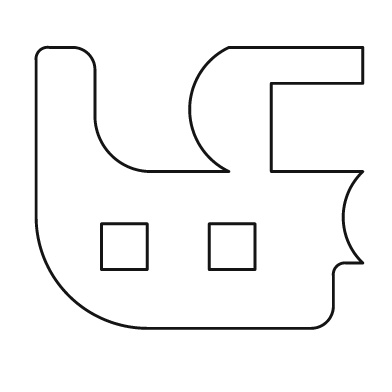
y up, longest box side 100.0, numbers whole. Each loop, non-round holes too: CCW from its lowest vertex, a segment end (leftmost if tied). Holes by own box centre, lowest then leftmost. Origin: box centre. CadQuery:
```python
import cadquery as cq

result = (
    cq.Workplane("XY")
    .moveTo(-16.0, -43.0)
    .lineTo(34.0, -43.0)
    .threePointArc((39.0, -41.0), (41.0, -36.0))
    .lineTo(41.0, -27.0)
    .threePointArc((42.0, -24.0), (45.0, -23.0))
    .lineTo(50.0, -23.0)
    .threePointArc((44.0, -9.0), (50.0, 5.0))
    .lineTo(22.0, 5.0)
    .lineTo(22.0, 32.0)
    .lineTo(50.0, 32.0)
    .lineTo(50.0, 43.0)
    .lineTo(9.0, 43.0)
    .threePointArc((-3.0, 24.0), (9.0, 5.0))
    .lineTo(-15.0, 5.0)
    .threePointArc((-27.0, 10.0), (-32.0, 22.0))
    .lineTo(-32.0, 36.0)
    .threePointArc((-34.0, 41.0), (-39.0, 43.0))
    .lineTo(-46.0, 43.0)
    .threePointArc((-49.0, 42.0), (-50.0, 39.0))
    .lineTo(-50.0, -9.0)
    .threePointArc((-40.0, -33.0), (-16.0, -43.0))
    .close()
    .moveTo(-30.0, -25.0)
    .lineTo(-16.0, -25.0)
    .lineTo(-16.0, -11.0)
    .lineTo(-30.0, -11.0)
    .close()
    .moveTo(3.0, -25.0)
    .lineTo(17.0, -25.0)
    .lineTo(17.0, -11.0)
    .lineTo(3.0, -11.0)
    .close()
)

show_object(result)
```